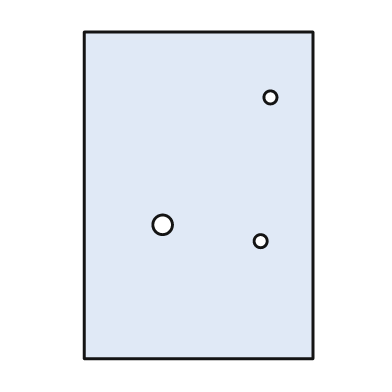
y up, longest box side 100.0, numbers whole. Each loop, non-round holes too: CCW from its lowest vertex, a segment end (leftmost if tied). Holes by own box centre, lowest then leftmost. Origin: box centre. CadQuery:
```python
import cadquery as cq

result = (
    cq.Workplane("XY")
    .moveTo(-35.0, -50.0)
    .lineTo(35.0, -50.0)
    .lineTo(35.0, 50.0)
    .lineTo(-35.0, 50.0)
    .close()
    .moveTo(19.0, -14.0)
    .circle(2.0)
    .moveTo(-11.0, -9.0)
    .circle(3.0)
    .moveTo(22.0, 30.0)
    .circle(2.0)
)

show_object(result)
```